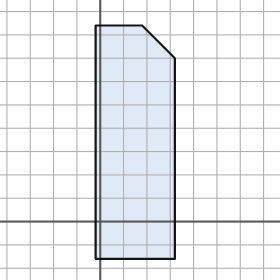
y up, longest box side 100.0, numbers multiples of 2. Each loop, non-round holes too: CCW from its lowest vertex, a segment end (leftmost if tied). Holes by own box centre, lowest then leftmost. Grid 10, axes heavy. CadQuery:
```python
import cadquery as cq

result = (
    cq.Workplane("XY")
    .moveTo(-2.0, -16.0)
    .lineTo(32.0, -16.0)
    .lineTo(32.0, 70.0)
    .lineTo(18.0, 84.0)
    .lineTo(-2.0, 84.0)
    .close()
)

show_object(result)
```